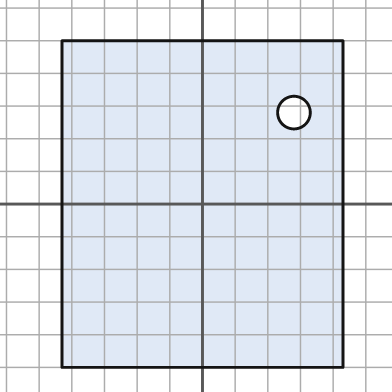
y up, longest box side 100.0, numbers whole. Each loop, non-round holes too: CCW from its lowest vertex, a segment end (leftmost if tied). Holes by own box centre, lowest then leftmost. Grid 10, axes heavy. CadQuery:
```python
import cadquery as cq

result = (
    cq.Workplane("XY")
    .moveTo(-43.0, -50.0)
    .lineTo(43.0, -50.0)
    .lineTo(43.0, 50.0)
    .lineTo(-43.0, 50.0)
    .close()
    .moveTo(28.0, 28.0)
    .circle(5.0)
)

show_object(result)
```